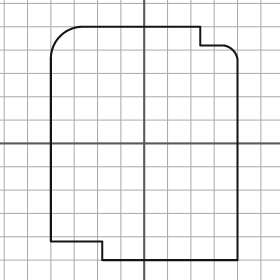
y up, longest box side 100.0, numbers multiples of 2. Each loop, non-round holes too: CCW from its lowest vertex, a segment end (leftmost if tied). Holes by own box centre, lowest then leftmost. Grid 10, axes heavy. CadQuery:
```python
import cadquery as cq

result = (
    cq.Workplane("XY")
    .moveTo(-18.0, -50.0)
    .lineTo(40.0, -50.0)
    .lineTo(40.0, 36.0)
    .threePointArc((38.0, 40.0), (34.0, 42.0))
    .lineTo(24.0, 42.0)
    .lineTo(24.0, 50.0)
    .lineTo(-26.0, 50.0)
    .threePointArc((-36.0, 46.0), (-40.0, 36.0))
    .lineTo(-40.0, -42.0)
    .lineTo(-18.0, -42.0)
    .close()
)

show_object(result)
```